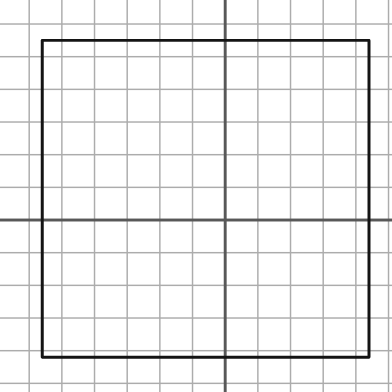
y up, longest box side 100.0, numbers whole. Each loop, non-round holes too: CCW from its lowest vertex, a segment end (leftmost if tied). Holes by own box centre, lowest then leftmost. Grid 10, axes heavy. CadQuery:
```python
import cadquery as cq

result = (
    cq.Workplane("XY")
    .moveTo(-56.0, -42.0)
    .lineTo(44.0, -42.0)
    .lineTo(44.0, 55.0)
    .lineTo(-56.0, 55.0)
    .close()
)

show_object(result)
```